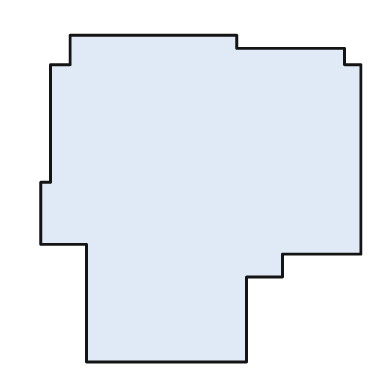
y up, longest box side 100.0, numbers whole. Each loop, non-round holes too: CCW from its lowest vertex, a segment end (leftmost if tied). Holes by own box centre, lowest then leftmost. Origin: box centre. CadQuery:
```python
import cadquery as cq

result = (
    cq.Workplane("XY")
    .moveTo(-35.0, -50.0)
    .lineTo(14.0, -50.0)
    .lineTo(14.0, -24.0)
    .lineTo(25.0, -24.0)
    .lineTo(25.0, -17.0)
    .lineTo(49.0, -17.0)
    .lineTo(49.0, 41.0)
    .lineTo(44.0, 41.0)
    .lineTo(44.0, 46.0)
    .lineTo(11.0, 46.0)
    .lineTo(11.0, 50.0)
    .lineTo(-40.0, 50.0)
    .lineTo(-40.0, 41.0)
    .lineTo(-46.0, 41.0)
    .lineTo(-46.0, 5.0)
    .lineTo(-49.0, 5.0)
    .lineTo(-49.0, -14.0)
    .lineTo(-35.0, -14.0)
    .close()
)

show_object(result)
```